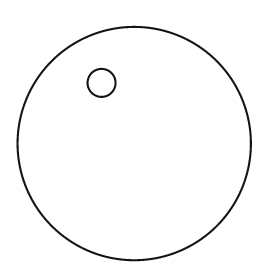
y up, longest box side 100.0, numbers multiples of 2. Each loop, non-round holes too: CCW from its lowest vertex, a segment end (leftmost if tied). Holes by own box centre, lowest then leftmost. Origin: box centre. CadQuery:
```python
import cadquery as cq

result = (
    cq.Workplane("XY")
    .moveTo(0.0, 0.0)
    .circle(50.0)
    .moveTo(-14.0, 26.0)
    .circle(6.0)
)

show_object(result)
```